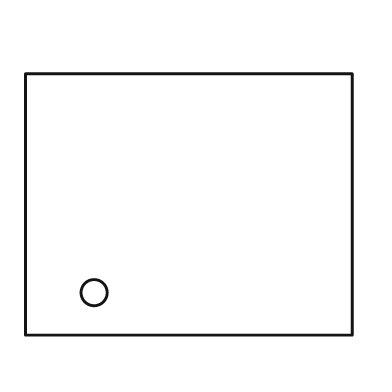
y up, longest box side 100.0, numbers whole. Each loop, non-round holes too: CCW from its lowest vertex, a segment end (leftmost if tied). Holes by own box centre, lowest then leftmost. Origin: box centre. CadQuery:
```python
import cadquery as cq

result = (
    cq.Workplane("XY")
    .moveTo(-50.0, -40.0)
    .lineTo(50.0, -40.0)
    .lineTo(50.0, 40.0)
    .lineTo(-50.0, 40.0)
    .close()
    .moveTo(-29.0, -27.0)
    .circle(4.0)
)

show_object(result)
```